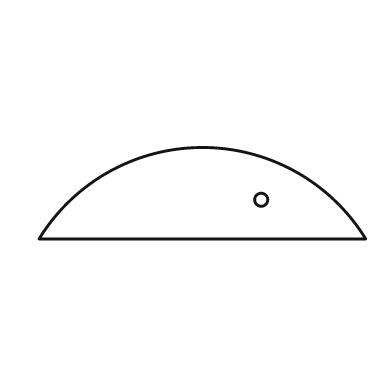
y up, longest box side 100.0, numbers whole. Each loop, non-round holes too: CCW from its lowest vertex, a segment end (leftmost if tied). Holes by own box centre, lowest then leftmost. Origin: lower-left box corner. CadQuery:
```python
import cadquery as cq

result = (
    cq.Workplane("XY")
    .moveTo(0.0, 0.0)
    .lineTo(100.0, 0.0)
    .threePointArc((50.0, 28.0), (0.0, 0.0))
    .close()
    .moveTo(68.0, 12.0)
    .circle(2.0)
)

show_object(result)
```